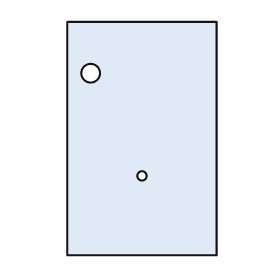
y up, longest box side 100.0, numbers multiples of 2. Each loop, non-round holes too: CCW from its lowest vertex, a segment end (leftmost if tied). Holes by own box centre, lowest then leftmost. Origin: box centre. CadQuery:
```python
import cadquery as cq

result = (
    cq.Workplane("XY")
    .moveTo(-32.0, -50.0)
    .lineTo(32.0, -50.0)
    .lineTo(32.0, 50.0)
    .lineTo(-32.0, 50.0)
    .close()
    .moveTo(0.0, -16.0)
    .circle(2.0)
    .moveTo(-22.0, 28.0)
    .circle(4.0)
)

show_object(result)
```